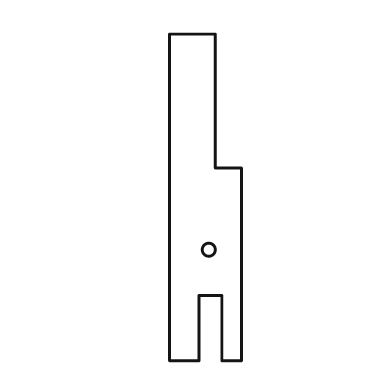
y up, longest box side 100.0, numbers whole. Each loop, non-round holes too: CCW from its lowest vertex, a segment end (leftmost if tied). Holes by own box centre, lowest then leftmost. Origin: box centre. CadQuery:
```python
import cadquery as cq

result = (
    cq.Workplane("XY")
    .moveTo(-11.0, -50.0)
    .lineTo(-2.0, -50.0)
    .lineTo(-2.0, -30.0)
    .lineTo(5.0, -30.0)
    .lineTo(5.0, -50.0)
    .lineTo(11.0, -50.0)
    .lineTo(11.0, 9.0)
    .lineTo(3.0, 9.0)
    .lineTo(3.0, 50.0)
    .lineTo(-11.0, 50.0)
    .close()
    .moveTo(1.0, -16.0)
    .circle(2.0)
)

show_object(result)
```